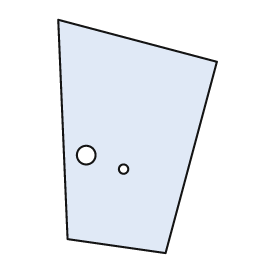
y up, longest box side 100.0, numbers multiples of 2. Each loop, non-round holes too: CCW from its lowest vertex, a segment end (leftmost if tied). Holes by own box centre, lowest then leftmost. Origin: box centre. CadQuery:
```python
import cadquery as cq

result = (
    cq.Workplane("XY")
    .moveTo(12.0, -50.0)
    .lineTo(34.0, 32.0)
    .lineTo(-34.0, 50.0)
    .lineTo(-30.0, -44.0)
    .close()
    .moveTo(-6.0, -14.0)
    .circle(2.0)
    .moveTo(-22.0, -8.0)
    .circle(4.0)
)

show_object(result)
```